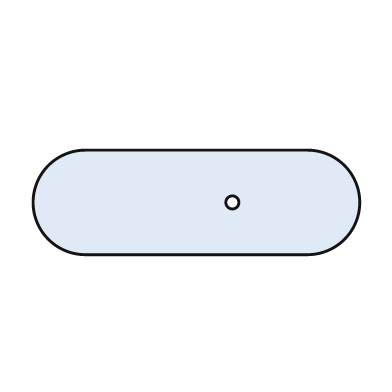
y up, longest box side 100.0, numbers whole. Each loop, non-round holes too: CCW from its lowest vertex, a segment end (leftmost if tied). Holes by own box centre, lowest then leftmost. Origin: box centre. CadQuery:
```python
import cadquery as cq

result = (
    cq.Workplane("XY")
    .moveTo(-34.0, -16.0)
    .lineTo(34.0, -16.0)
    .threePointArc((50.0, 0.0), (34.0, 16.0))
    .lineTo(-34.0, 16.0)
    .threePointArc((-50.0, 0.0), (-34.0, -16.0))
    .close()
    .moveTo(11.0, 0.0)
    .circle(2.0)
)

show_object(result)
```